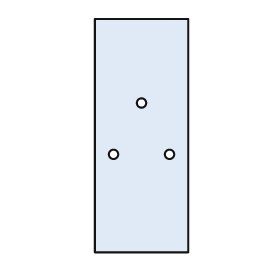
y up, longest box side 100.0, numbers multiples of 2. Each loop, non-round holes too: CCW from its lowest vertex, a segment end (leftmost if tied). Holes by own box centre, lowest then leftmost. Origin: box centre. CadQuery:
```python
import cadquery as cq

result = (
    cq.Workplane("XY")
    .moveTo(-20.0, -50.0)
    .lineTo(20.0, -50.0)
    .lineTo(20.0, 50.0)
    .lineTo(-20.0, 50.0)
    .close()
    .moveTo(-12.0, -8.0)
    .circle(2.0)
    .moveTo(12.0, -8.0)
    .circle(2.0)
    .moveTo(0.0, 14.0)
    .circle(2.0)
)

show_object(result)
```